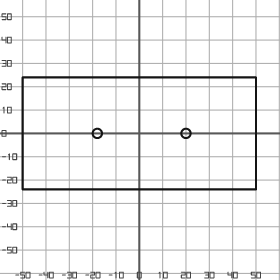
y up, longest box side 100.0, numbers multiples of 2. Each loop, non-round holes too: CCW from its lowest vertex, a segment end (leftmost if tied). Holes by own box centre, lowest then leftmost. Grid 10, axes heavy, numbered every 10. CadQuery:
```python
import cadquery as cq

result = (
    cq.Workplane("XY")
    .moveTo(-50.0, -24.0)
    .lineTo(50.0, -24.0)
    .lineTo(50.0, 24.0)
    .lineTo(-50.0, 24.0)
    .close()
    .moveTo(-18.0, 0.0)
    .circle(2.0)
    .moveTo(20.0, 0.0)
    .circle(2.0)
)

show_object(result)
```